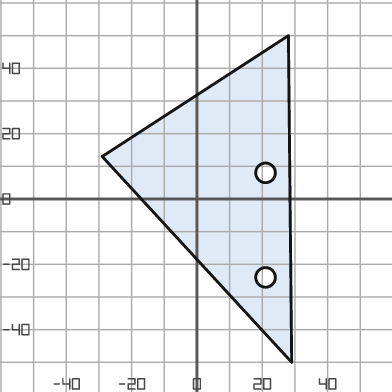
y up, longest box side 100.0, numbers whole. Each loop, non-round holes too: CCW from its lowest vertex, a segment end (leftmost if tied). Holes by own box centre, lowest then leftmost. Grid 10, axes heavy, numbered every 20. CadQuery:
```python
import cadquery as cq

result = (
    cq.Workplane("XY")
    .moveTo(29.0, -50.0)
    .lineTo(28.0, 50.0)
    .lineTo(-29.0, 13.0)
    .close()
    .moveTo(21.0, -24.0)
    .circle(3.0)
    .moveTo(21.0, 8.0)
    .circle(3.0)
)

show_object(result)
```